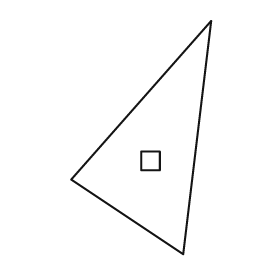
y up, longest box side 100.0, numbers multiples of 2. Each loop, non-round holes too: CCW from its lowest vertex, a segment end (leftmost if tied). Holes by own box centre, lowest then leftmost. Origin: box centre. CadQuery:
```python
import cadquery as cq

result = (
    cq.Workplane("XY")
    .moveTo(18.0, -50.0)
    .lineTo(30.0, 50.0)
    .lineTo(-30.0, -18.0)
    .close()
    .moveTo(0.0, -14.0)
    .lineTo(8.0, -14.0)
    .lineTo(8.0, -6.0)
    .lineTo(0.0, -6.0)
    .close()
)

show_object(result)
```